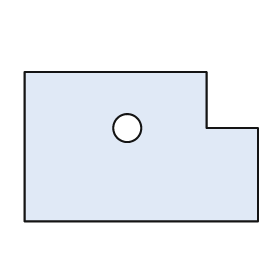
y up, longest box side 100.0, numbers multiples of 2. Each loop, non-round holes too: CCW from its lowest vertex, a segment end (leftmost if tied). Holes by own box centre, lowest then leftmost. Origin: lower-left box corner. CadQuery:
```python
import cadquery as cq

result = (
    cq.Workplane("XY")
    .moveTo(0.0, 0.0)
    .lineTo(100.0, 0.0)
    .lineTo(100.0, 40.0)
    .lineTo(78.0, 40.0)
    .lineTo(78.0, 64.0)
    .lineTo(0.0, 64.0)
    .close()
    .moveTo(44.0, 40.0)
    .circle(6.0)
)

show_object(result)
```